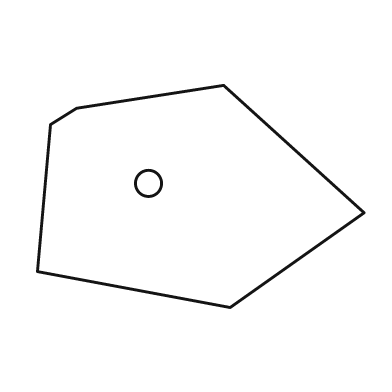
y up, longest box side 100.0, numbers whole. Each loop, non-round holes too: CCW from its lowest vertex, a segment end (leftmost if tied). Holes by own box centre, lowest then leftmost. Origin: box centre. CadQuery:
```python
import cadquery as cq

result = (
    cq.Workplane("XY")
    .moveTo(9.0, -34.0)
    .lineTo(50.0, -5.0)
    .lineTo(7.0, 34.0)
    .lineTo(-38.0, 27.0)
    .lineTo(-46.0, 22.0)
    .lineTo(-50.0, -23.0)
    .close()
    .moveTo(-16.0, 4.0)
    .circle(4.0)
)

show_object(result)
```